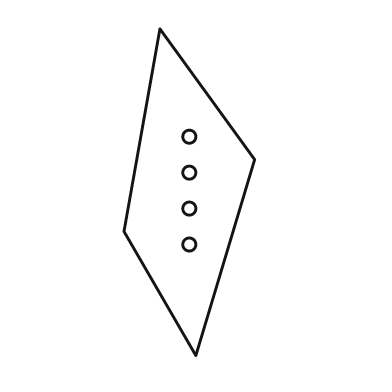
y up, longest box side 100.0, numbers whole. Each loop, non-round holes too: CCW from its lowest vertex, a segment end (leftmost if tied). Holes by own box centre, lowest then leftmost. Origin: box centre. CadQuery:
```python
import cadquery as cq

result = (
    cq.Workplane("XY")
    .moveTo(2.0, -50.0)
    .lineTo(20.0, 10.0)
    .lineTo(-9.0, 50.0)
    .lineTo(-20.0, -12.0)
    .close()
    .moveTo(0.0, -16.0)
    .circle(2.0)
    .moveTo(0.0, -5.0)
    .circle(2.0)
    .moveTo(0.0, 6.0)
    .circle(2.0)
    .moveTo(0.0, 17.0)
    .circle(2.0)
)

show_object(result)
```